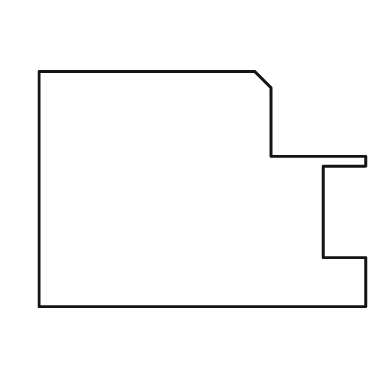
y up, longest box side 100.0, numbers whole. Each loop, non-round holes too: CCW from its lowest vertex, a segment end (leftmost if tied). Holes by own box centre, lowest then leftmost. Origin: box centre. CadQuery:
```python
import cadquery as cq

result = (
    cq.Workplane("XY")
    .moveTo(-50.0, -36.0)
    .lineTo(50.0, -36.0)
    .lineTo(50.0, -21.0)
    .lineTo(37.0, -21.0)
    .lineTo(37.0, 7.0)
    .lineTo(50.0, 7.0)
    .lineTo(50.0, 10.0)
    .lineTo(21.0, 10.0)
    .lineTo(21.0, 31.0)
    .lineTo(16.0, 36.0)
    .lineTo(-50.0, 36.0)
    .close()
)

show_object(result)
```